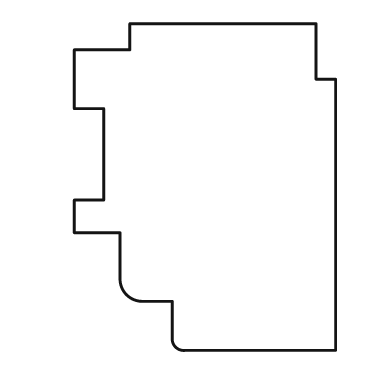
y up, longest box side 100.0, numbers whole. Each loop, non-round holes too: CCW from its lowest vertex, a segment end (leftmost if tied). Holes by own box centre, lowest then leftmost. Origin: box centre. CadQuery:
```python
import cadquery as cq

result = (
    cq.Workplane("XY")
    .moveTo(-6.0, -50.0)
    .lineTo(40.0, -50.0)
    .lineTo(40.0, 33.0)
    .lineTo(34.0, 33.0)
    .lineTo(34.0, 50.0)
    .lineTo(-23.0, 50.0)
    .lineTo(-23.0, 42.0)
    .lineTo(-40.0, 42.0)
    .lineTo(-40.0, 24.0)
    .lineTo(-31.0, 24.0)
    .lineTo(-31.0, -4.0)
    .lineTo(-40.0, -4.0)
    .lineTo(-40.0, -14.0)
    .lineTo(-26.0, -14.0)
    .lineTo(-26.0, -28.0)
    .threePointArc((-24.0, -33.0), (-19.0, -35.0))
    .lineTo(-10.0, -35.0)
    .lineTo(-10.0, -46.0)
    .threePointArc((-9.0, -49.0), (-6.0, -50.0))
    .close()
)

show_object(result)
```